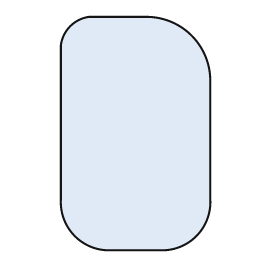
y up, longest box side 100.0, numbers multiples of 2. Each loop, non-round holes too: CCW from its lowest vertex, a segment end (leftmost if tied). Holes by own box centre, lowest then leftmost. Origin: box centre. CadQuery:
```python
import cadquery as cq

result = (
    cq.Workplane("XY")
    .moveTo(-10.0, -50.0)
    .lineTo(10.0, -50.0)
    .threePointArc((26.0, -44.0), (32.0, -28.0))
    .lineTo(32.0, 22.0)
    .threePointArc((24.0, 42.0), (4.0, 50.0))
    .lineTo(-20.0, 50.0)
    .threePointArc((-28.0, 46.0), (-32.0, 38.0))
    .lineTo(-32.0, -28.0)
    .threePointArc((-26.0, -44.0), (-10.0, -50.0))
    .close()
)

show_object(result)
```